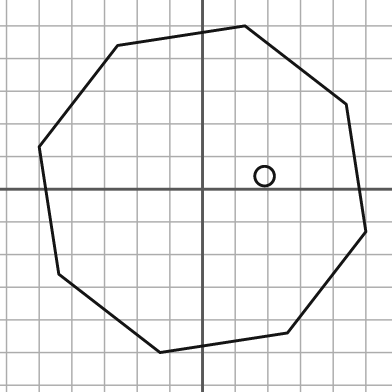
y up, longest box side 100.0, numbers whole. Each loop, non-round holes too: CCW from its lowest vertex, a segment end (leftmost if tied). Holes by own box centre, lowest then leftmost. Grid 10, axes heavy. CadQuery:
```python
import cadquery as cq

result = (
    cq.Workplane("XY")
    .moveTo(-13.0, -50.0)
    .lineTo(26.0, -44.0)
    .lineTo(50.0, -13.0)
    .lineTo(44.0, 26.0)
    .lineTo(13.0, 50.0)
    .lineTo(-26.0, 44.0)
    .lineTo(-50.0, 13.0)
    .lineTo(-44.0, -26.0)
    .close()
    .moveTo(19.0, 4.0)
    .circle(3.0)
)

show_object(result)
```